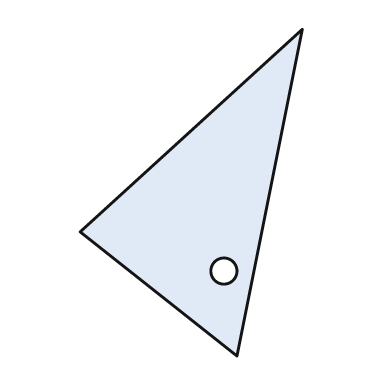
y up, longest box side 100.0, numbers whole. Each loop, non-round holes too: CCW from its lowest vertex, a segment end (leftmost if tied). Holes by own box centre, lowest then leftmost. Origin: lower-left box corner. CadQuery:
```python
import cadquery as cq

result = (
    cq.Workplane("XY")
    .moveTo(48.0, 0.0)
    .lineTo(68.0, 100.0)
    .lineTo(0.0, 38.0)
    .close()
    .moveTo(44.0, 26.0)
    .circle(4.0)
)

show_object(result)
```